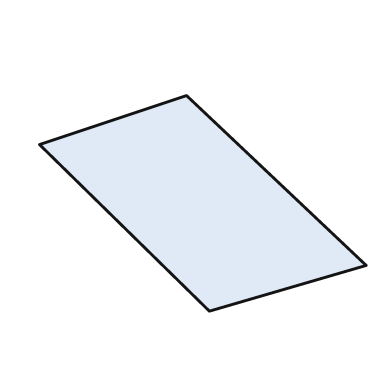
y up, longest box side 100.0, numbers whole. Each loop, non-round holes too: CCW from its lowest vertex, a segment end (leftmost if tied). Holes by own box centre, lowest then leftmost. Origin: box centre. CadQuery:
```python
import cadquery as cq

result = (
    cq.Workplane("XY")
    .moveTo(2.0, -33.0)
    .lineTo(50.0, -19.0)
    .lineTo(-5.0, 33.0)
    .lineTo(-50.0, 18.0)
    .close()
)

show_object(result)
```